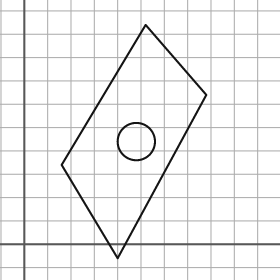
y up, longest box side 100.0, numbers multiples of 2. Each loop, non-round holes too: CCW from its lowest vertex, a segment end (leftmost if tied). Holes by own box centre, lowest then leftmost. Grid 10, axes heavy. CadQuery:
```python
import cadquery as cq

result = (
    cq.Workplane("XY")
    .moveTo(40.0, -6.0)
    .lineTo(78.0, 64.0)
    .lineTo(52.0, 94.0)
    .lineTo(16.0, 34.0)
    .close()
    .moveTo(48.0, 44.0)
    .circle(8.0)
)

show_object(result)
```